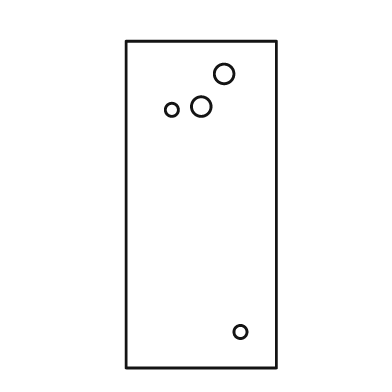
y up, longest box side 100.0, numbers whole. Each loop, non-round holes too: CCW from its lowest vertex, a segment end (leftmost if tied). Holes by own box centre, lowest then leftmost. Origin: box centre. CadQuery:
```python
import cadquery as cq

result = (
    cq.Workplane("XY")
    .moveTo(-23.0, -50.0)
    .lineTo(23.0, -50.0)
    .lineTo(23.0, 50.0)
    .lineTo(-23.0, 50.0)
    .close()
    .moveTo(12.0, -39.0)
    .circle(2.0)
    .moveTo(-9.0, 29.0)
    .circle(2.0)
    .moveTo(0.0, 30.0)
    .circle(3.0)
    .moveTo(7.0, 40.0)
    .circle(3.0)
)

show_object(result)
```